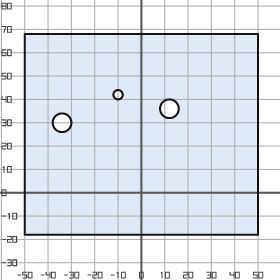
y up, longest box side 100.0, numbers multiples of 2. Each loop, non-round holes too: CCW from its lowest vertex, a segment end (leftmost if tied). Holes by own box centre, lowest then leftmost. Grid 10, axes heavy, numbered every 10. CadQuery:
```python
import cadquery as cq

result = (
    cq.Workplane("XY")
    .moveTo(-50.0, -18.0)
    .lineTo(50.0, -18.0)
    .lineTo(50.0, 68.0)
    .lineTo(-50.0, 68.0)
    .close()
    .moveTo(-34.0, 30.0)
    .circle(4.0)
    .moveTo(12.0, 36.0)
    .circle(4.0)
    .moveTo(-10.0, 42.0)
    .circle(2.0)
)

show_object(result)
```